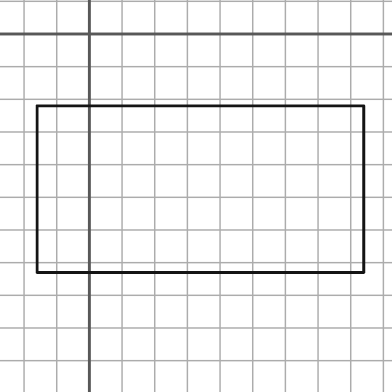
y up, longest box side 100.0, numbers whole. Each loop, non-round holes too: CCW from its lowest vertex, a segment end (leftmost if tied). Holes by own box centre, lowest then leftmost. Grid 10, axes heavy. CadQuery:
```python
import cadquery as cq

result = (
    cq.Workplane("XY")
    .moveTo(-16.0, -73.0)
    .lineTo(84.0, -73.0)
    .lineTo(84.0, -22.0)
    .lineTo(-16.0, -22.0)
    .close()
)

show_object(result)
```